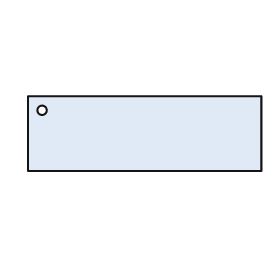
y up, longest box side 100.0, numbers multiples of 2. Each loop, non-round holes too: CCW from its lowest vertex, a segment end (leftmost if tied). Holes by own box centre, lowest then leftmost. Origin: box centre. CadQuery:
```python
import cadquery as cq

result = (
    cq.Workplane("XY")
    .moveTo(-50.0, -16.0)
    .lineTo(50.0, -16.0)
    .lineTo(50.0, 16.0)
    .lineTo(-50.0, 16.0)
    .close()
    .moveTo(-44.0, 10.0)
    .circle(2.0)
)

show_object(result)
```